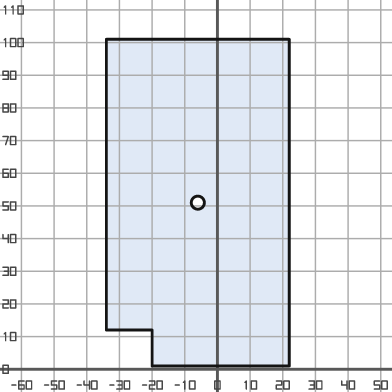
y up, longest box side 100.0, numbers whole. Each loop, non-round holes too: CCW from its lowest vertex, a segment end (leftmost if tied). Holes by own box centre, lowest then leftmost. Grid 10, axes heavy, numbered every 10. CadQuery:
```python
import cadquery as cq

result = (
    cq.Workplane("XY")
    .moveTo(-20.0, 1.0)
    .lineTo(22.0, 1.0)
    .lineTo(22.0, 101.0)
    .lineTo(-34.0, 101.0)
    .lineTo(-34.0, 12.0)
    .lineTo(-20.0, 12.0)
    .close()
    .moveTo(-6.0, 51.0)
    .circle(2.0)
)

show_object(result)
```